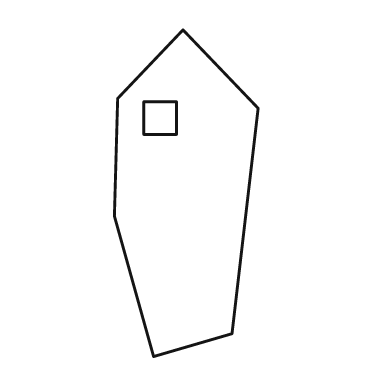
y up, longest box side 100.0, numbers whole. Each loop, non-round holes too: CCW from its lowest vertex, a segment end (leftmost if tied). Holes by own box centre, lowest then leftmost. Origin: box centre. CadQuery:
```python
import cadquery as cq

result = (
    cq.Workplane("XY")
    .moveTo(-10.0, -50.0)
    .lineTo(14.0, -43.0)
    .lineTo(22.0, 26.0)
    .lineTo(-1.0, 50.0)
    .lineTo(-21.0, 29.0)
    .lineTo(-22.0, -7.0)
    .close()
    .moveTo(-13.0, 18.0)
    .lineTo(-3.0, 18.0)
    .lineTo(-3.0, 28.0)
    .lineTo(-13.0, 28.0)
    .close()
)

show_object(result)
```